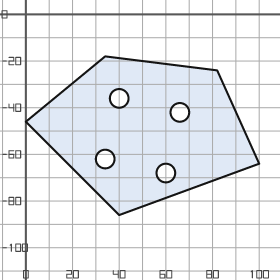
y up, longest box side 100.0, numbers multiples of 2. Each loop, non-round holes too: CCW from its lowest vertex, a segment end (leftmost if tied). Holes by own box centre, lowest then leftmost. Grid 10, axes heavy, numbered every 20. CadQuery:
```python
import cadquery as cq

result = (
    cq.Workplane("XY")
    .moveTo(40.0, -86.0)
    .lineTo(100.0, -64.0)
    .lineTo(82.0, -24.0)
    .lineTo(34.0, -18.0)
    .lineTo(0.0, -46.0)
    .close()
    .moveTo(60.0, -68.0)
    .circle(4.0)
    .moveTo(34.0, -62.0)
    .circle(4.0)
    .moveTo(66.0, -42.0)
    .circle(4.0)
    .moveTo(40.0, -36.0)
    .circle(4.0)
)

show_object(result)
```